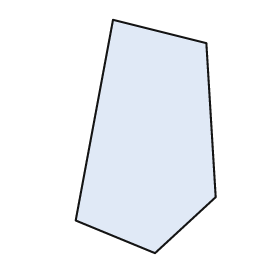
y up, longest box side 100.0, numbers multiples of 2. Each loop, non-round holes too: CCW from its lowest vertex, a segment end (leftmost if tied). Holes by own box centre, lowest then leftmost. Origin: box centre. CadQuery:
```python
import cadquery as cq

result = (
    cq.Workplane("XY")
    .moveTo(4.0, -50.0)
    .lineTo(30.0, -26.0)
    .lineTo(26.0, 40.0)
    .lineTo(-14.0, 50.0)
    .lineTo(-30.0, -36.0)
    .close()
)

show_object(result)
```